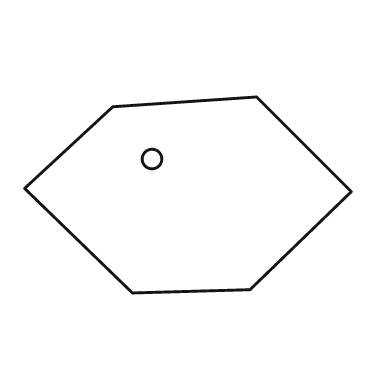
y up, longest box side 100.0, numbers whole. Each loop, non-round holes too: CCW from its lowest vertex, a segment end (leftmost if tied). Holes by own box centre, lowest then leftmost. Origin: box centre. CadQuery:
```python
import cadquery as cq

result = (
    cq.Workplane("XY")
    .moveTo(-17.0, -30.0)
    .lineTo(19.0, -29.0)
    .lineTo(50.0, 1.0)
    .lineTo(21.0, 30.0)
    .lineTo(-23.0, 27.0)
    .lineTo(-50.0, 2.0)
    .close()
    .moveTo(-11.0, 11.0)
    .circle(3.0)
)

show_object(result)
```